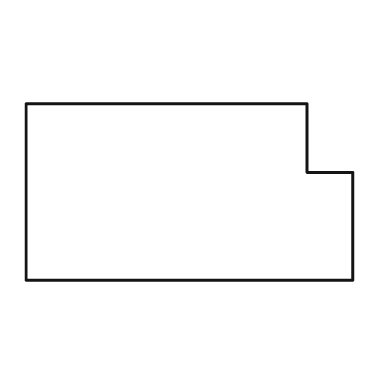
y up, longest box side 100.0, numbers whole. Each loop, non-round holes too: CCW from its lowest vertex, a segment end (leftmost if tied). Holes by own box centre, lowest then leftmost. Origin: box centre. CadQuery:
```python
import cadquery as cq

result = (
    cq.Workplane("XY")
    .moveTo(-50.0, -27.0)
    .lineTo(50.0, -27.0)
    .lineTo(50.0, 6.0)
    .lineTo(36.0, 6.0)
    .lineTo(36.0, 27.0)
    .lineTo(-50.0, 27.0)
    .close()
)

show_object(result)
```